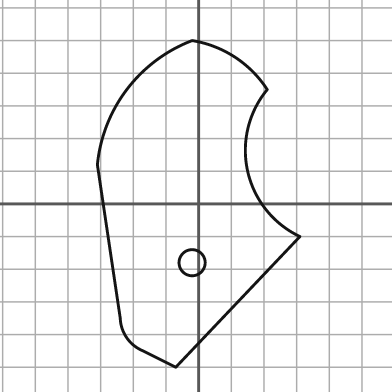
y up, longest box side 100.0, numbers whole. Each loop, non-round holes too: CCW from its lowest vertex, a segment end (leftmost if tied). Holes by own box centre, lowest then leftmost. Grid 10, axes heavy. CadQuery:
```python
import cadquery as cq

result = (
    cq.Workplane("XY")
    .moveTo(-7.0, -50.0)
    .lineTo(31.0, -10.0)
    .threePointArc((15.0, 10.0), (21.0, 35.0))
    .threePointArc((11.0, 45.0), (-2.0, 50.0))
    .threePointArc((-22.0, 35.0), (-31.0, 12.0))
    .lineTo(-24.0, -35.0)
    .threePointArc((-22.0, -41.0), (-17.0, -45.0))
    .close()
    .moveTo(-2.0, -18.0)
    .circle(4.0)
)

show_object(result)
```